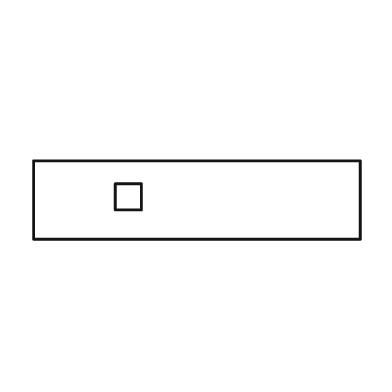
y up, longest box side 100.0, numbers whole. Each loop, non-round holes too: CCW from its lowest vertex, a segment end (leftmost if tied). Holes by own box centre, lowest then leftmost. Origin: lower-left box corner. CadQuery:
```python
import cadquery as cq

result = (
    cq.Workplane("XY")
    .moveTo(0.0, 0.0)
    .lineTo(100.0, 0.0)
    .lineTo(100.0, 24.0)
    .lineTo(0.0, 24.0)
    .close()
    .moveTo(25.0, 9.0)
    .lineTo(33.0, 9.0)
    .lineTo(33.0, 17.0)
    .lineTo(25.0, 17.0)
    .close()
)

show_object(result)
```